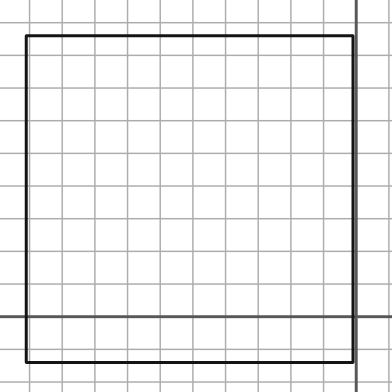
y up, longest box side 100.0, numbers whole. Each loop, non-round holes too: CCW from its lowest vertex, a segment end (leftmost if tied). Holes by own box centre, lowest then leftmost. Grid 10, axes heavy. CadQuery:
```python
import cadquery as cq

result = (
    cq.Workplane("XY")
    .moveTo(-101.0, -14.0)
    .lineTo(-1.0, -14.0)
    .lineTo(-1.0, 86.0)
    .lineTo(-101.0, 86.0)
    .close()
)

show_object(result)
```